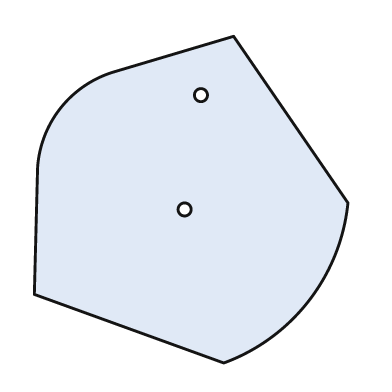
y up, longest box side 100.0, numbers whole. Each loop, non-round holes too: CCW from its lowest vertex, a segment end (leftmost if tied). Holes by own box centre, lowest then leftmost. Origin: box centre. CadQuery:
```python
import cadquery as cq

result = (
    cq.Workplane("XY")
    .moveTo(10.0, -50.0)
    .threePointArc((36.0, -31.0), (48.0, -1.0))
    .lineTo(13.0, 50.0)
    .lineTo(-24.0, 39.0)
    .threePointArc((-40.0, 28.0), (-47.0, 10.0))
    .lineTo(-48.0, -29.0)
    .close()
    .moveTo(-2.0, -3.0)
    .circle(2.0)
    .moveTo(3.0, 32.0)
    .circle(2.0)
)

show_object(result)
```